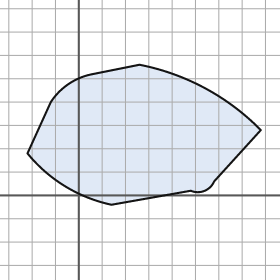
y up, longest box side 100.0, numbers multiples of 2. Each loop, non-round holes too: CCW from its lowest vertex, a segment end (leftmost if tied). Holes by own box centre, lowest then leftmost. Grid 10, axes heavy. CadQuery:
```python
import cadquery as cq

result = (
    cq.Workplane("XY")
    .moveTo(14.0, -4.0)
    .lineTo(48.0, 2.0)
    .threePointArc((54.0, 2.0), (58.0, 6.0))
    .lineTo(78.0, 28.0)
    .threePointArc((54.0, 46.0), (26.0, 56.0))
    .lineTo(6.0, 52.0)
    .threePointArc((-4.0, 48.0), (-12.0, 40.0))
    .lineTo(-22.0, 18.0)
    .threePointArc((-6.0, 4.0), (14.0, -4.0))
    .close()
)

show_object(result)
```